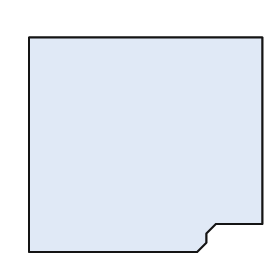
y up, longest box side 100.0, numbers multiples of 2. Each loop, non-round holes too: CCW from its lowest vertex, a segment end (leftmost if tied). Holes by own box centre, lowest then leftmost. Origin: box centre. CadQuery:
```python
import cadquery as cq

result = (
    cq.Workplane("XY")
    .moveTo(-50.0, -46.0)
    .lineTo(22.0, -46.0)
    .lineTo(26.0, -42.0)
    .lineTo(26.0, -38.0)
    .lineTo(30.0, -34.0)
    .lineTo(50.0, -34.0)
    .lineTo(50.0, 46.0)
    .lineTo(-50.0, 46.0)
    .close()
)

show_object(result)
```